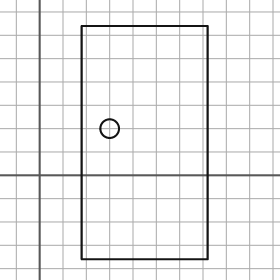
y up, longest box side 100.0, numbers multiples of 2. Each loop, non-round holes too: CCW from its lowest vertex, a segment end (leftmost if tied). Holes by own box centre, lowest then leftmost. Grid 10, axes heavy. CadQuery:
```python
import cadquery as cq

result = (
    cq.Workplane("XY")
    .moveTo(18.0, -36.0)
    .lineTo(72.0, -36.0)
    .lineTo(72.0, 64.0)
    .lineTo(18.0, 64.0)
    .close()
    .moveTo(30.0, 20.0)
    .circle(4.0)
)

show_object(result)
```